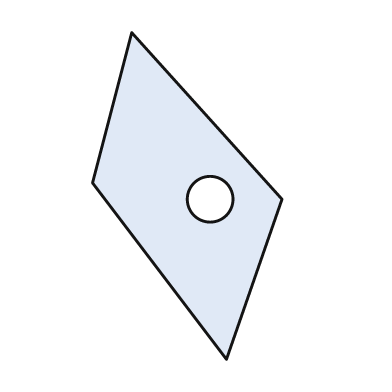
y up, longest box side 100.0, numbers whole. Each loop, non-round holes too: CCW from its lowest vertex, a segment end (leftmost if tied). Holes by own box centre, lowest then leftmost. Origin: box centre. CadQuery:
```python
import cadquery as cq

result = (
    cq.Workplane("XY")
    .moveTo(12.0, -50.0)
    .lineTo(29.0, -1.0)
    .lineTo(-17.0, 50.0)
    .lineTo(-29.0, 4.0)
    .close()
    .moveTo(7.0, -1.0)
    .circle(7.0)
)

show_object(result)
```